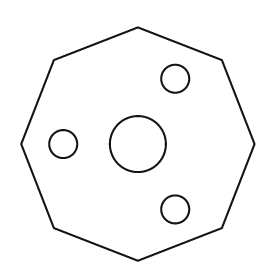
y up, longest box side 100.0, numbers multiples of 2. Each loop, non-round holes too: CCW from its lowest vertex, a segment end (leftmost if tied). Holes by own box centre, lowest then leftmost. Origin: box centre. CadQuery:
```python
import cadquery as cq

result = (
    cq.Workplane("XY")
    .moveTo(0.0, -50.0)
    .lineTo(36.0, -36.0)
    .lineTo(50.0, 0.0)
    .lineTo(36.0, 36.0)
    .lineTo(0.0, 50.0)
    .lineTo(-36.0, 36.0)
    .lineTo(-50.0, 0.0)
    .lineTo(-36.0, -36.0)
    .close()
    .moveTo(16.0, -28.0)
    .circle(6.0)
    .moveTo(-32.0, 0.0)
    .circle(6.0)
    .moveTo(0.0, 0.0)
    .circle(12.0)
    .moveTo(16.0, 28.0)
    .circle(6.0)
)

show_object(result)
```